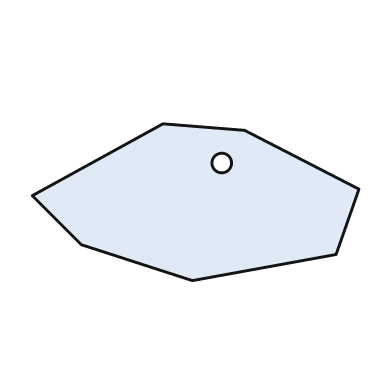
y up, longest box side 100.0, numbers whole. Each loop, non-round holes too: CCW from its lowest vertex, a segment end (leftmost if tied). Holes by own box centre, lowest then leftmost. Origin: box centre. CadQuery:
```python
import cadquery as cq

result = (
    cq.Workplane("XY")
    .moveTo(-1.0, -24.0)
    .lineTo(43.0, -16.0)
    .lineTo(50.0, 4.0)
    .lineTo(15.0, 22.0)
    .lineTo(-10.0, 24.0)
    .lineTo(-50.0, 2.0)
    .lineTo(-35.0, -13.0)
    .close()
    .moveTo(8.0, 12.0)
    .circle(3.0)
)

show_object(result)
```